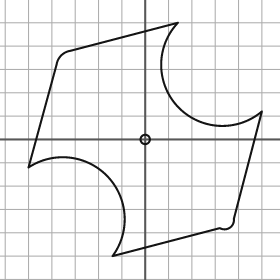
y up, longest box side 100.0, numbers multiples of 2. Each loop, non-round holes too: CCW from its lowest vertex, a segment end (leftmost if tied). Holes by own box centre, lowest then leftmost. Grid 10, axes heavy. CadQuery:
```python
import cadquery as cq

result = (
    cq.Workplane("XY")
    .moveTo(-14.0, -50.0)
    .lineTo(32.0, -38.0)
    .threePointArc((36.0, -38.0), (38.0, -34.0))
    .lineTo(50.0, 12.0)
    .threePointArc((14.0, 14.0), (14.0, 50.0))
    .lineTo(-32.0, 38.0)
    .threePointArc((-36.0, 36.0), (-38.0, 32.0))
    .lineTo(-50.0, -12.0)
    .threePointArc((-16.0, -16.0), (-14.0, -50.0))
    .close()
    .moveTo(0.0, 0.0)
    .circle(2.0)
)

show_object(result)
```